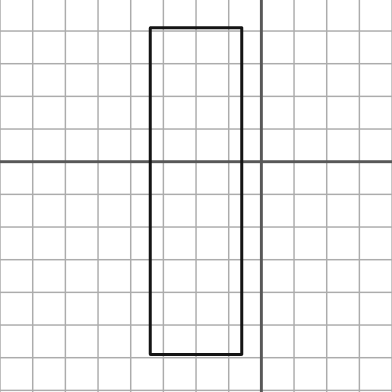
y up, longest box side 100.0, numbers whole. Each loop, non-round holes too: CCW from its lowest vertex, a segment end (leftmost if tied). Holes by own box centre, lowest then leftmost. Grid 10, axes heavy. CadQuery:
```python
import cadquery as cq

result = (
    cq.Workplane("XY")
    .moveTo(-34.0, -59.0)
    .lineTo(-6.0, -59.0)
    .lineTo(-6.0, 41.0)
    .lineTo(-34.0, 41.0)
    .close()
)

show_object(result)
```